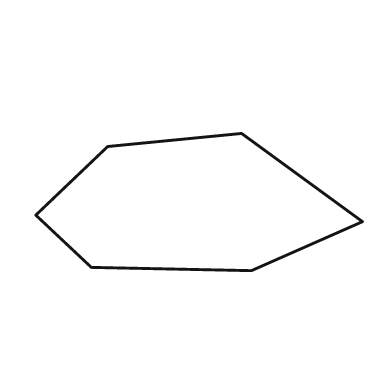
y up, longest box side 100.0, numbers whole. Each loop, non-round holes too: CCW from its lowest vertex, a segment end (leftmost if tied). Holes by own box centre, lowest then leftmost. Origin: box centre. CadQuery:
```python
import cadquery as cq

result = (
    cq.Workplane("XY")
    .moveTo(16.0, -21.0)
    .lineTo(50.0, -6.0)
    .lineTo(13.0, 21.0)
    .lineTo(-28.0, 17.0)
    .lineTo(-50.0, -4.0)
    .lineTo(-33.0, -20.0)
    .close()
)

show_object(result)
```